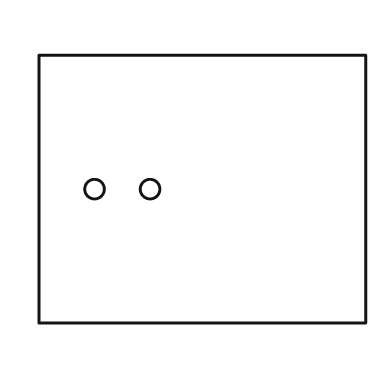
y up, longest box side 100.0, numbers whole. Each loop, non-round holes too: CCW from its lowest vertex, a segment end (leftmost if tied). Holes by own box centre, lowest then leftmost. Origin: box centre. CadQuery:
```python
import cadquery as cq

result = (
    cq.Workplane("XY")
    .moveTo(-50.0, -41.0)
    .lineTo(50.0, -41.0)
    .lineTo(50.0, 41.0)
    .lineTo(-50.0, 41.0)
    .close()
    .moveTo(-33.0, 0.0)
    .circle(3.0)
    .moveTo(-16.0, 0.0)
    .circle(3.0)
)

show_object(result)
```